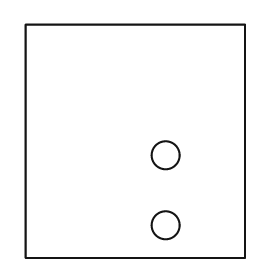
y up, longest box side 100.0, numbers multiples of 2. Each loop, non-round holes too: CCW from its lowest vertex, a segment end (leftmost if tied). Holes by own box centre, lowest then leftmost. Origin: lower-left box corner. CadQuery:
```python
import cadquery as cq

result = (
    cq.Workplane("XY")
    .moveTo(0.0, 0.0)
    .lineTo(94.0, 0.0)
    .lineTo(94.0, 100.0)
    .lineTo(0.0, 100.0)
    .close()
    .moveTo(60.0, 14.0)
    .circle(6.0)
    .moveTo(60.0, 44.0)
    .circle(6.0)
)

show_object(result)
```